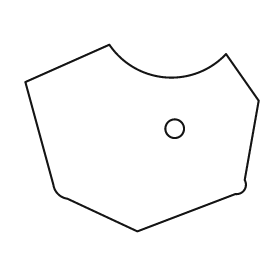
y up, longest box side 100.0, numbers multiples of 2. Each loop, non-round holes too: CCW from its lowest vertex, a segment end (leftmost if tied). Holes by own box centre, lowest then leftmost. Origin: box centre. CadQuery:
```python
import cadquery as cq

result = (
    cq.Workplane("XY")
    .moveTo(-2.0, -40.0)
    .lineTo(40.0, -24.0)
    .threePointArc((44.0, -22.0), (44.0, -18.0))
    .lineTo(50.0, 16.0)
    .lineTo(36.0, 36.0)
    .threePointArc((10.0, 26.0), (-14.0, 40.0))
    .lineTo(-50.0, 24.0)
    .lineTo(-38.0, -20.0)
    .threePointArc((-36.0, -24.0), (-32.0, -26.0))
    .close()
    .moveTo(14.0, 4.0)
    .circle(4.0)
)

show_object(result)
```